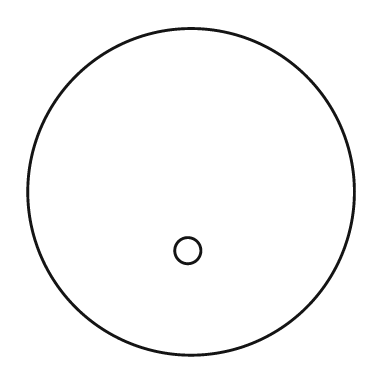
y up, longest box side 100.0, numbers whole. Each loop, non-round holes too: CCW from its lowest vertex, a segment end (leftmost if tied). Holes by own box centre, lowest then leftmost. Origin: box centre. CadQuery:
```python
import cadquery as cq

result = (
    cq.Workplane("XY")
    .moveTo(0.0, 0.0)
    .circle(50.0)
    .moveTo(-1.0, -18.0)
    .circle(4.0)
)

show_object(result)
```